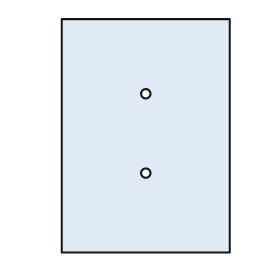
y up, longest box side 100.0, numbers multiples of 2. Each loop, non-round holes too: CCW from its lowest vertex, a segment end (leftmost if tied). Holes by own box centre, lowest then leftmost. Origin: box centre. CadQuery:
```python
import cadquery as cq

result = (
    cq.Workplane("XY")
    .moveTo(-36.0, -50.0)
    .lineTo(36.0, -50.0)
    .lineTo(36.0, 50.0)
    .lineTo(-36.0, 50.0)
    .close()
    .moveTo(0.0, -16.0)
    .circle(2.0)
    .moveTo(0.0, 18.0)
    .circle(2.0)
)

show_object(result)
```